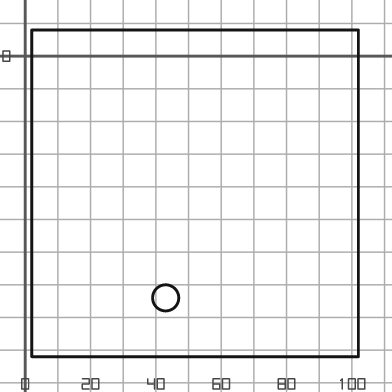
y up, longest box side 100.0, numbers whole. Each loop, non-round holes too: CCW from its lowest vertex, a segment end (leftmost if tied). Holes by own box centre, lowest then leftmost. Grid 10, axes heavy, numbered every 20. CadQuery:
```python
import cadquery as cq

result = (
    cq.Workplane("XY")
    .moveTo(2.0, -92.0)
    .lineTo(102.0, -92.0)
    .lineTo(102.0, 8.0)
    .lineTo(2.0, 8.0)
    .close()
    .moveTo(43.0, -74.0)
    .circle(4.0)
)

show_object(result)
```